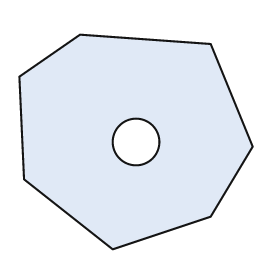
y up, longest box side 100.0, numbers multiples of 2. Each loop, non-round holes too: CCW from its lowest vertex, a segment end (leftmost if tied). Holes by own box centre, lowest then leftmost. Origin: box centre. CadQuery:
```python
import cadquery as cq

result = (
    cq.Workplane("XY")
    .moveTo(-10.0, -46.0)
    .lineTo(32.0, -32.0)
    .lineTo(50.0, -2.0)
    .lineTo(32.0, 42.0)
    .lineTo(-24.0, 46.0)
    .lineTo(-50.0, 28.0)
    .lineTo(-48.0, -16.0)
    .close()
    .moveTo(0.0, 0.0)
    .circle(10.0)
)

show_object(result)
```